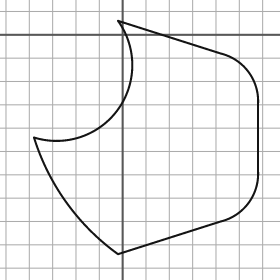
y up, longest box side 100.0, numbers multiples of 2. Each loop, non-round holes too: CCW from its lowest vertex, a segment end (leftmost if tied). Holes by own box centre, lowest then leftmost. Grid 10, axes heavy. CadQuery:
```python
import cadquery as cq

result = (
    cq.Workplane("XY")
    .moveTo(-2.0, -94.0)
    .lineTo(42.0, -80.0)
    .threePointArc((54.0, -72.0), (58.0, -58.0))
    .lineTo(58.0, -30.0)
    .threePointArc((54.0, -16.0), (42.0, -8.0))
    .lineTo(-2.0, 6.0)
    .threePointArc((-2.0, -32.0), (-38.0, -44.0))
    .threePointArc((-24.0, -72.0), (-2.0, -94.0))
    .close()
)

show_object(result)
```